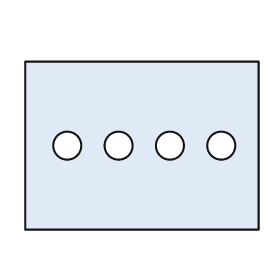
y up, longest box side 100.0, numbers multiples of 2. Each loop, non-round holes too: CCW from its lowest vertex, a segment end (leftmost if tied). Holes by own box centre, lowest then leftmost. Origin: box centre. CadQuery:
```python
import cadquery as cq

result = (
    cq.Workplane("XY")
    .moveTo(-50.0, -36.0)
    .lineTo(50.0, -36.0)
    .lineTo(50.0, 36.0)
    .lineTo(-50.0, 36.0)
    .close()
    .moveTo(-32.0, 0.0)
    .circle(6.0)
    .moveTo(-10.0, 0.0)
    .circle(6.0)
    .moveTo(12.0, 0.0)
    .circle(6.0)
    .moveTo(34.0, 0.0)
    .circle(6.0)
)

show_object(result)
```